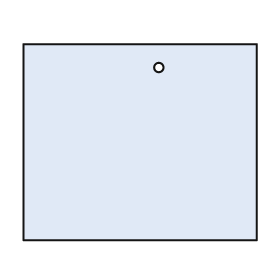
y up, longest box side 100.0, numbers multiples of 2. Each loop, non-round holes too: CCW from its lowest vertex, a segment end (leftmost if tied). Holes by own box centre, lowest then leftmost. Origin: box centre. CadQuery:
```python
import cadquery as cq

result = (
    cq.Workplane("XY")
    .moveTo(-50.0, -42.0)
    .lineTo(50.0, -42.0)
    .lineTo(50.0, 42.0)
    .lineTo(-50.0, 42.0)
    .close()
    .moveTo(8.0, 32.0)
    .circle(2.0)
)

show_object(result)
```